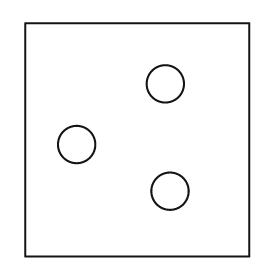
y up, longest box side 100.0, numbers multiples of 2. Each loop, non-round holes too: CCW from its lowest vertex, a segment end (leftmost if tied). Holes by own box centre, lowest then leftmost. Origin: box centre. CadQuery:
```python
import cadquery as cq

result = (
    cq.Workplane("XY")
    .moveTo(-48.0, -50.0)
    .lineTo(48.0, -50.0)
    .lineTo(48.0, 50.0)
    .lineTo(-48.0, 50.0)
    .close()
    .moveTo(14.0, -22.0)
    .circle(8.0)
    .moveTo(-26.0, -2.0)
    .circle(8.0)
    .moveTo(12.0, 24.0)
    .circle(8.0)
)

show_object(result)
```